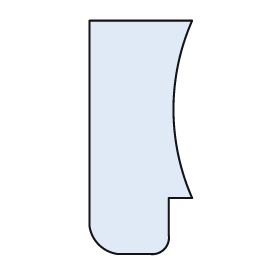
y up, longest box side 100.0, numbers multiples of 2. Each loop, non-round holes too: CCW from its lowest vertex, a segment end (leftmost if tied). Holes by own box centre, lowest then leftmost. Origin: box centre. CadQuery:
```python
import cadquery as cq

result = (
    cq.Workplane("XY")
    .moveTo(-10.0, -50.0)
    .lineTo(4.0, -50.0)
    .threePointArc((10.0, -48.0), (12.0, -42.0))
    .lineTo(12.0, -26.0)
    .lineTo(22.0, -26.0)
    .threePointArc((14.0, 12.0), (22.0, 50.0))
    .lineTo(-22.0, 50.0)
    .lineTo(-22.0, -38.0)
    .threePointArc((-18.0, -46.0), (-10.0, -50.0))
    .close()
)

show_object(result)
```